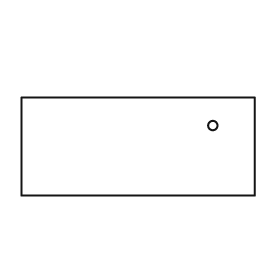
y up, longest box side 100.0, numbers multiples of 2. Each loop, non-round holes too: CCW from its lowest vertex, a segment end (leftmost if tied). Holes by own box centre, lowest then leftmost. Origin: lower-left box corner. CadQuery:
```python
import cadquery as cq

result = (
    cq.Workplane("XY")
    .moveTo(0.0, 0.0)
    .lineTo(100.0, 0.0)
    .lineTo(100.0, 42.0)
    .lineTo(0.0, 42.0)
    .close()
    .moveTo(82.0, 30.0)
    .circle(2.0)
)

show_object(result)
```